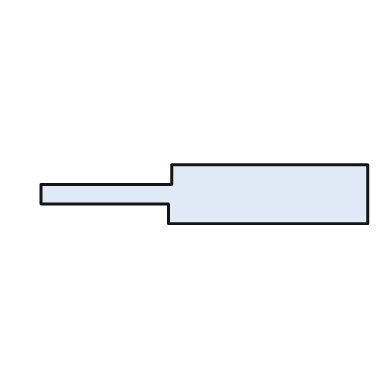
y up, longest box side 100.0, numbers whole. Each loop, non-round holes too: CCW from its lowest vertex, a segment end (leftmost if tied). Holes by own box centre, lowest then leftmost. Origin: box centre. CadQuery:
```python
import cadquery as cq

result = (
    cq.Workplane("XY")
    .moveTo(-11.0, -9.0)
    .lineTo(50.0, -9.0)
    .lineTo(50.0, 9.0)
    .lineTo(-10.0, 9.0)
    .lineTo(-10.0, 3.0)
    .lineTo(-50.0, 3.0)
    .lineTo(-50.0, -3.0)
    .lineTo(-11.0, -3.0)
    .close()
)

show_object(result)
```